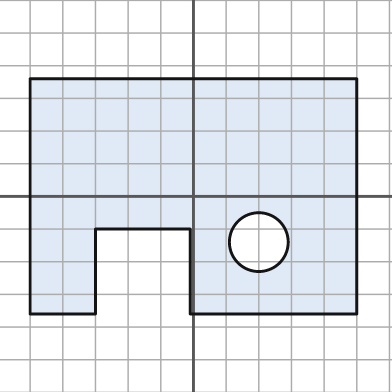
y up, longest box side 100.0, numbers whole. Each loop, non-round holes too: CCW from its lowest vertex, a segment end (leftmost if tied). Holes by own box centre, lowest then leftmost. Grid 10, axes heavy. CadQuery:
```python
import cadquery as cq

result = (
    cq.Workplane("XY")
    .moveTo(-50.0, -36.0)
    .lineTo(-30.0, -36.0)
    .lineTo(-30.0, -10.0)
    .lineTo(-1.0, -10.0)
    .lineTo(-1.0, -36.0)
    .lineTo(50.0, -36.0)
    .lineTo(50.0, 36.0)
    .lineTo(-50.0, 36.0)
    .close()
    .moveTo(20.0, -14.0)
    .circle(9.0)
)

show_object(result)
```